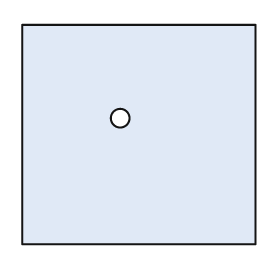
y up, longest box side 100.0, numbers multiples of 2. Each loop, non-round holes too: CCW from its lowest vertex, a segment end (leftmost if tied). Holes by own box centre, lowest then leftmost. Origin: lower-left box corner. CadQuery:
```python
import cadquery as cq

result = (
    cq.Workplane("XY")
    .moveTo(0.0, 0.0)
    .lineTo(100.0, 0.0)
    .lineTo(100.0, 94.0)
    .lineTo(0.0, 94.0)
    .close()
    .moveTo(42.0, 54.0)
    .circle(4.0)
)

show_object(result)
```